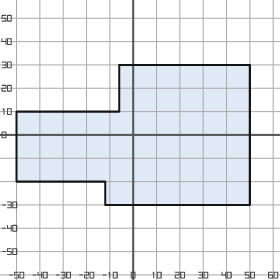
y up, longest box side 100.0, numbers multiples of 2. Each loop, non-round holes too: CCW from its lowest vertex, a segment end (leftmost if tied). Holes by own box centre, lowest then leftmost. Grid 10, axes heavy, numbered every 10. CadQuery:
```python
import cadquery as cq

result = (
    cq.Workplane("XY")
    .moveTo(-12.0, -30.0)
    .lineTo(50.0, -30.0)
    .lineTo(50.0, 30.0)
    .lineTo(-6.0, 30.0)
    .lineTo(-6.0, 10.0)
    .lineTo(-50.0, 10.0)
    .lineTo(-50.0, -20.0)
    .lineTo(-12.0, -20.0)
    .close()
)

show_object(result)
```